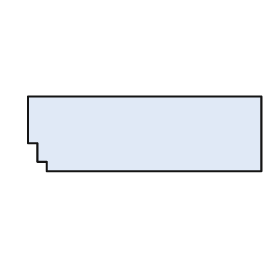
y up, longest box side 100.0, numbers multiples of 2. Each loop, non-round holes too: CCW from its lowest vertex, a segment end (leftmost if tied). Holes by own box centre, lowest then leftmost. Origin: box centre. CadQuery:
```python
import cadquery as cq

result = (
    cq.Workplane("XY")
    .moveTo(-42.0, -16.0)
    .lineTo(50.0, -16.0)
    .lineTo(50.0, 16.0)
    .lineTo(-50.0, 16.0)
    .lineTo(-50.0, -4.0)
    .lineTo(-46.0, -4.0)
    .lineTo(-46.0, -12.0)
    .lineTo(-42.0, -12.0)
    .close()
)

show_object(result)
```